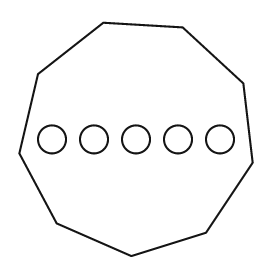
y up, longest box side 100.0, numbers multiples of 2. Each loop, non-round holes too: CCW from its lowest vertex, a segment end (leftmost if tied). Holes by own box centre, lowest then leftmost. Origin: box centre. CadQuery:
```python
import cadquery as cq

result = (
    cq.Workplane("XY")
    .moveTo(-2.0, -50.0)
    .lineTo(30.0, -40.0)
    .lineTo(50.0, -10.0)
    .lineTo(46.0, 24.0)
    .lineTo(20.0, 48.0)
    .lineTo(-14.0, 50.0)
    .lineTo(-42.0, 28.0)
    .lineTo(-50.0, -6.0)
    .lineTo(-34.0, -36.0)
    .close()
    .moveTo(-36.0, 0.0)
    .circle(6.0)
    .moveTo(-18.0, 0.0)
    .circle(6.0)
    .moveTo(0.0, 0.0)
    .circle(6.0)
    .moveTo(18.0, 0.0)
    .circle(6.0)
    .moveTo(36.0, 0.0)
    .circle(6.0)
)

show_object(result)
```